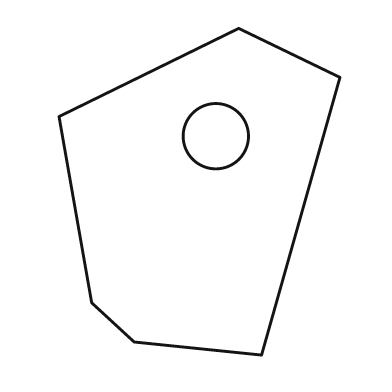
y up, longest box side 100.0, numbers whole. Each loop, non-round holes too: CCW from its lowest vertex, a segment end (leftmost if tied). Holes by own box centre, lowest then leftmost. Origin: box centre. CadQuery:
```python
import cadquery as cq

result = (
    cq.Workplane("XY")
    .moveTo(19.0, -50.0)
    .lineTo(43.0, 35.0)
    .lineTo(12.0, 50.0)
    .lineTo(-43.0, 23.0)
    .lineTo(-33.0, -34.0)
    .lineTo(-20.0, -46.0)
    .close()
    .moveTo(5.0, 17.0)
    .circle(10.0)
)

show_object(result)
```